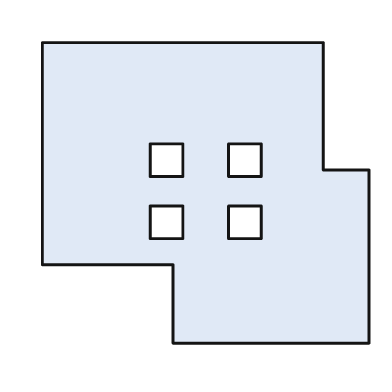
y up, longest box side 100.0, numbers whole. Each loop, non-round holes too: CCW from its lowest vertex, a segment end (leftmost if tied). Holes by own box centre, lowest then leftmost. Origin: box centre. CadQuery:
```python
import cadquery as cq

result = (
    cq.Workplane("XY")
    .moveTo(-10.0, -46.0)
    .lineTo(50.0, -46.0)
    .lineTo(50.0, 7.0)
    .lineTo(36.0, 7.0)
    .lineTo(36.0, 46.0)
    .lineTo(-50.0, 46.0)
    .lineTo(-50.0, -22.0)
    .lineTo(-10.0, -22.0)
    .close()
    .moveTo(-17.0, -14.0)
    .lineTo(-7.0, -14.0)
    .lineTo(-7.0, -4.0)
    .lineTo(-17.0, -4.0)
    .close()
    .moveTo(7.0, -14.0)
    .lineTo(17.0, -14.0)
    .lineTo(17.0, -4.0)
    .lineTo(7.0, -4.0)
    .close()
    .moveTo(-17.0, 5.0)
    .lineTo(-7.0, 5.0)
    .lineTo(-7.0, 15.0)
    .lineTo(-17.0, 15.0)
    .close()
    .moveTo(7.0, 5.0)
    .lineTo(17.0, 5.0)
    .lineTo(17.0, 15.0)
    .lineTo(7.0, 15.0)
    .close()
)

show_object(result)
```